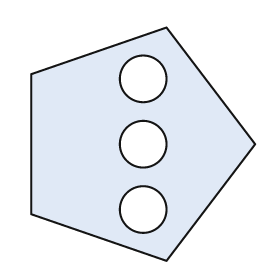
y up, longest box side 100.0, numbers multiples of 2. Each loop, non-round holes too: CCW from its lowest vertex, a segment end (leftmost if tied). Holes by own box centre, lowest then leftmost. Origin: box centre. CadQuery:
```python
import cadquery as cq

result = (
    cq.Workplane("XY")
    .moveTo(10.0, -50.0)
    .lineTo(48.0, 0.0)
    .lineTo(10.0, 50.0)
    .lineTo(-48.0, 30.0)
    .lineTo(-48.0, -30.0)
    .close()
    .moveTo(0.0, -28.0)
    .circle(10.0)
    .moveTo(0.0, 0.0)
    .circle(10.0)
    .moveTo(0.0, 28.0)
    .circle(10.0)
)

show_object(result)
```